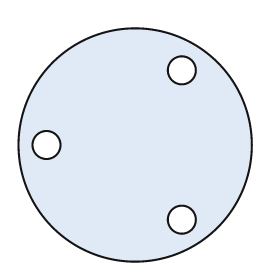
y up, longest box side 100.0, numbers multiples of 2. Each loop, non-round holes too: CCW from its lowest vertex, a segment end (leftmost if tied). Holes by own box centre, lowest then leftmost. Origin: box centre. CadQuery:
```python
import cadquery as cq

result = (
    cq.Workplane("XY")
    .moveTo(0.0, 0.0)
    .circle(50.0)
    .moveTo(20.0, -32.0)
    .circle(6.0)
    .moveTo(-38.0, 0.0)
    .circle(6.0)
    .moveTo(20.0, 32.0)
    .circle(6.0)
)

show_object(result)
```